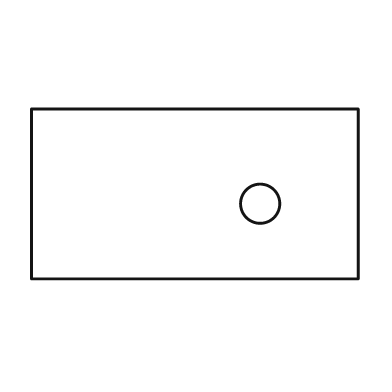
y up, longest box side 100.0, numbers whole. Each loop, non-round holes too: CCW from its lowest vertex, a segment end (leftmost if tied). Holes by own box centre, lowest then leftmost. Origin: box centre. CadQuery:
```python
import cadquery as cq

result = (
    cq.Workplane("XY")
    .moveTo(-50.0, -26.0)
    .lineTo(50.0, -26.0)
    .lineTo(50.0, 26.0)
    .lineTo(-50.0, 26.0)
    .close()
    .moveTo(20.0, -3.0)
    .circle(6.0)
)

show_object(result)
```